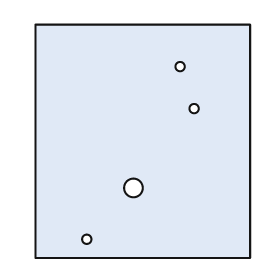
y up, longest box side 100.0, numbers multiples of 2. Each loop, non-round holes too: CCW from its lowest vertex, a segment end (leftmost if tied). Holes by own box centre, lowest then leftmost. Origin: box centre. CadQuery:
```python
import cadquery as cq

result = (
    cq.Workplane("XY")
    .moveTo(-46.0, -50.0)
    .lineTo(46.0, -50.0)
    .lineTo(46.0, 50.0)
    .lineTo(-46.0, 50.0)
    .close()
    .moveTo(-24.0, -42.0)
    .circle(2.0)
    .moveTo(-4.0, -20.0)
    .circle(4.0)
    .moveTo(22.0, 14.0)
    .circle(2.0)
    .moveTo(16.0, 32.0)
    .circle(2.0)
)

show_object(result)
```